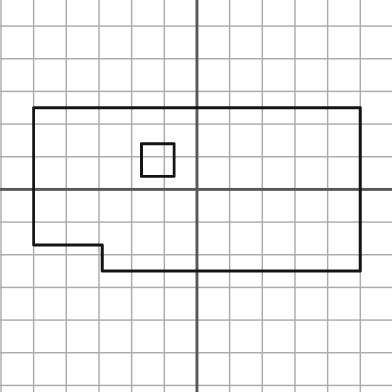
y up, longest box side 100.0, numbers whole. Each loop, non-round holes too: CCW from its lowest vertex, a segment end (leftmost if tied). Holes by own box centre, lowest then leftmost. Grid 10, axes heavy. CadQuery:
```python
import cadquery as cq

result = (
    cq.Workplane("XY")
    .moveTo(-29.0, -25.0)
    .lineTo(50.0, -25.0)
    .lineTo(50.0, 25.0)
    .lineTo(-50.0, 25.0)
    .lineTo(-50.0, -17.0)
    .lineTo(-29.0, -17.0)
    .close()
    .moveTo(-17.0, 4.0)
    .lineTo(-7.0, 4.0)
    .lineTo(-7.0, 14.0)
    .lineTo(-17.0, 14.0)
    .close()
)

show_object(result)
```